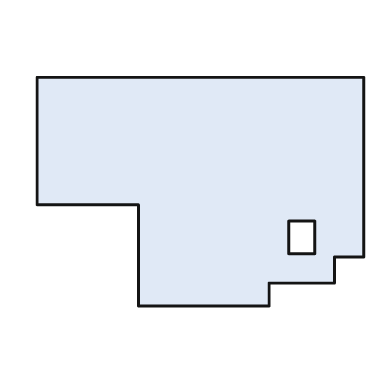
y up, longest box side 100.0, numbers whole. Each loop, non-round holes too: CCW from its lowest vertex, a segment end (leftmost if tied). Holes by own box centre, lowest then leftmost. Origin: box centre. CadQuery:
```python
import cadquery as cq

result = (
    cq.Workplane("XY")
    .moveTo(-19.0, -35.0)
    .lineTo(21.0, -35.0)
    .lineTo(21.0, -28.0)
    .lineTo(41.0, -28.0)
    .lineTo(41.0, -20.0)
    .lineTo(50.0, -20.0)
    .lineTo(50.0, 35.0)
    .lineTo(-50.0, 35.0)
    .lineTo(-50.0, -4.0)
    .lineTo(-19.0, -4.0)
    .close()
    .moveTo(27.0, -19.0)
    .lineTo(35.0, -19.0)
    .lineTo(35.0, -9.0)
    .lineTo(27.0, -9.0)
    .close()
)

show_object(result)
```